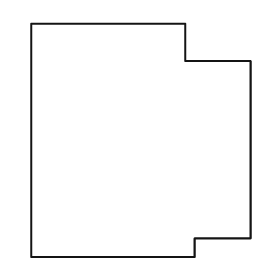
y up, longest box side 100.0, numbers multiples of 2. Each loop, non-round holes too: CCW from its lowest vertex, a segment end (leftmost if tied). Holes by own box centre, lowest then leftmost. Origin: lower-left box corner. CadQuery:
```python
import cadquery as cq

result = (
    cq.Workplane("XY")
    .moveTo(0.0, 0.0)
    .lineTo(70.0, 0.0)
    .lineTo(70.0, 8.0)
    .lineTo(94.0, 8.0)
    .lineTo(94.0, 84.0)
    .lineTo(66.0, 84.0)
    .lineTo(66.0, 100.0)
    .lineTo(0.0, 100.0)
    .close()
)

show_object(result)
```